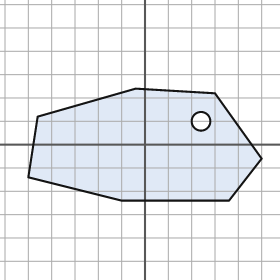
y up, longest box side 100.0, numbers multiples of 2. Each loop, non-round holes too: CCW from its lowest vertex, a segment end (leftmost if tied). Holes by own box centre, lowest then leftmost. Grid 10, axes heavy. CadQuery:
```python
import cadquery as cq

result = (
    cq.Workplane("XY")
    .moveTo(-10.0, -24.0)
    .lineTo(36.0, -24.0)
    .lineTo(50.0, -6.0)
    .lineTo(30.0, 22.0)
    .lineTo(-4.0, 24.0)
    .lineTo(-46.0, 12.0)
    .lineTo(-50.0, -14.0)
    .close()
    .moveTo(24.0, 10.0)
    .circle(4.0)
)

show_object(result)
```